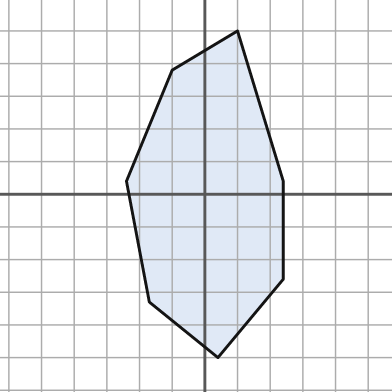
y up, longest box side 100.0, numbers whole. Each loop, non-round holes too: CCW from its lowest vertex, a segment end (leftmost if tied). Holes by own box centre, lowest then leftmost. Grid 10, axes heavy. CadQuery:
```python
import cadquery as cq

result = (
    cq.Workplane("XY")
    .moveTo(4.0, -50.0)
    .lineTo(24.0, -26.0)
    .lineTo(24.0, 4.0)
    .lineTo(10.0, 50.0)
    .lineTo(-10.0, 38.0)
    .lineTo(-24.0, 4.0)
    .lineTo(-17.0, -33.0)
    .close()
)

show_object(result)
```